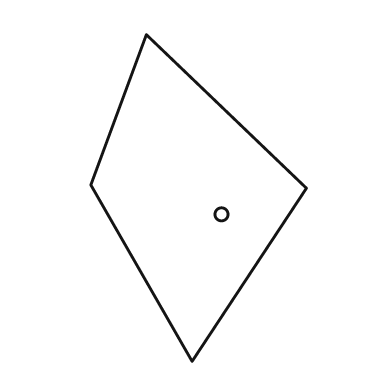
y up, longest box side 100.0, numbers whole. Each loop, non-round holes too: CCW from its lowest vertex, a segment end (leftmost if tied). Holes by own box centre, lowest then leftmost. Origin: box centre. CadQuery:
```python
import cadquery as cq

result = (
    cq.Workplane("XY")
    .moveTo(-2.0, -50.0)
    .lineTo(33.0, 3.0)
    .lineTo(-16.0, 50.0)
    .lineTo(-33.0, 4.0)
    .close()
    .moveTo(7.0, -5.0)
    .circle(2.0)
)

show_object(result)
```